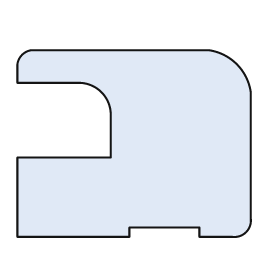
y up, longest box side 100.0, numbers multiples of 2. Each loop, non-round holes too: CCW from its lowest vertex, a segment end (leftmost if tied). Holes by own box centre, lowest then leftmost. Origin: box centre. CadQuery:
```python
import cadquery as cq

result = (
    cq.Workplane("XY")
    .moveTo(-50.0, -40.0)
    .lineTo(-2.0, -40.0)
    .lineTo(-2.0, -36.0)
    .lineTo(28.0, -36.0)
    .lineTo(28.0, -40.0)
    .lineTo(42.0, -40.0)
    .threePointArc((48.0, -38.0), (50.0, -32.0))
    .lineTo(50.0, 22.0)
    .threePointArc((44.0, 34.0), (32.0, 40.0))
    .lineTo(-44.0, 40.0)
    .threePointArc((-48.0, 38.0), (-50.0, 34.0))
    .lineTo(-50.0, 26.0)
    .lineTo(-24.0, 26.0)
    .threePointArc((-14.0, 22.0), (-10.0, 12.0))
    .lineTo(-10.0, -6.0)
    .lineTo(-50.0, -6.0)
    .close()
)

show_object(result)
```